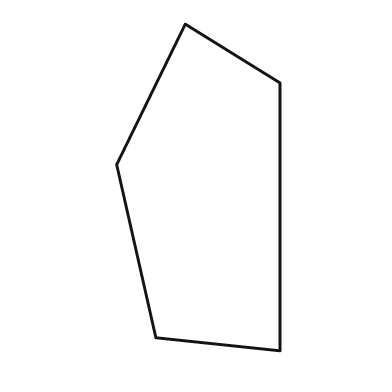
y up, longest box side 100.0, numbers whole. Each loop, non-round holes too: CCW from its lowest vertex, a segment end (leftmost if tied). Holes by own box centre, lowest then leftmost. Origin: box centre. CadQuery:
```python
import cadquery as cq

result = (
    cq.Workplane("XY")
    .moveTo(25.0, -50.0)
    .lineTo(25.0, 32.0)
    .lineTo(-4.0, 50.0)
    .lineTo(-25.0, 7.0)
    .lineTo(-13.0, -46.0)
    .close()
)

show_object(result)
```